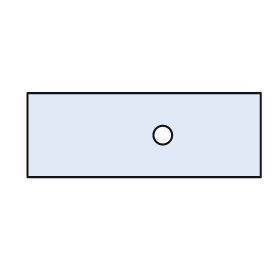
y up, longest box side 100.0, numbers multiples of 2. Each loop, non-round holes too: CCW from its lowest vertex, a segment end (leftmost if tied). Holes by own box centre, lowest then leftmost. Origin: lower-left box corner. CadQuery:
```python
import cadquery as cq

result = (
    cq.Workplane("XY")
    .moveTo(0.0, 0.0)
    .lineTo(100.0, 0.0)
    .lineTo(100.0, 36.0)
    .lineTo(0.0, 36.0)
    .close()
    .moveTo(58.0, 18.0)
    .circle(4.0)
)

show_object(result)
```